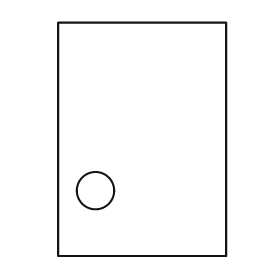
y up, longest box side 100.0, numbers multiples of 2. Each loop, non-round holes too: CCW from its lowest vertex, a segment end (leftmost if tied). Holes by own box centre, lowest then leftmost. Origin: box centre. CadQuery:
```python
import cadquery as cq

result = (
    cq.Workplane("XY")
    .moveTo(-36.0, -50.0)
    .lineTo(36.0, -50.0)
    .lineTo(36.0, 50.0)
    .lineTo(-36.0, 50.0)
    .close()
    .moveTo(-20.0, -22.0)
    .circle(8.0)
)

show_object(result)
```